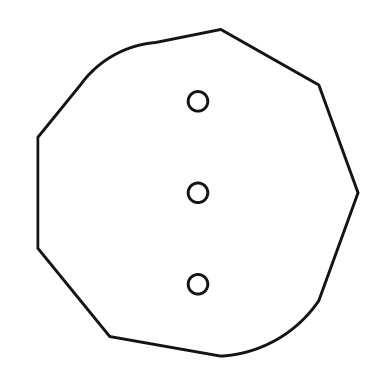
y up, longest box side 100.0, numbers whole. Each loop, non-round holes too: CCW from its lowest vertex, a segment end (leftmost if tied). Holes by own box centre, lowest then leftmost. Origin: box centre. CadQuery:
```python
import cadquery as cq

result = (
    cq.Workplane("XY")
    .moveTo(7.0, -50.0)
    .threePointArc((24.0, -45.0), (37.0, -33.0))
    .lineTo(49.0, 0.0)
    .lineTo(37.0, 33.0)
    .lineTo(7.0, 50.0)
    .lineTo(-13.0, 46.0)
    .threePointArc((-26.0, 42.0), (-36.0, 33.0))
    .lineTo(-49.0, 17.0)
    .lineTo(-49.0, -17.0)
    .lineTo(-27.0, -44.0)
    .close()
    .moveTo(0.0, -28.0)
    .circle(3.0)
    .moveTo(0.0, 0.0)
    .circle(3.0)
    .moveTo(0.0, 28.0)
    .circle(3.0)
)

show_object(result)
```